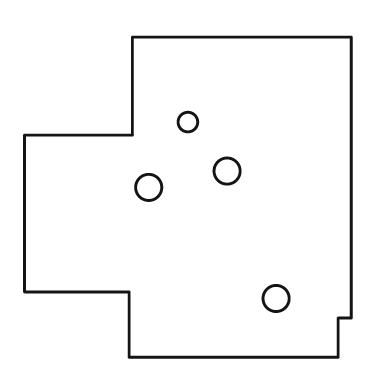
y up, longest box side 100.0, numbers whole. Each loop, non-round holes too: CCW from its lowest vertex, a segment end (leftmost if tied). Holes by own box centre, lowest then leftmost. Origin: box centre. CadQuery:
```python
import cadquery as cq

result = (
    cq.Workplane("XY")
    .moveTo(-18.0, -49.0)
    .lineTo(46.0, -49.0)
    .lineTo(46.0, -37.0)
    .lineTo(50.0, -37.0)
    .lineTo(50.0, 49.0)
    .lineTo(-17.0, 49.0)
    .lineTo(-17.0, 19.0)
    .lineTo(-50.0, 19.0)
    .lineTo(-50.0, -29.0)
    .lineTo(-18.0, -29.0)
    .close()
    .moveTo(27.0, -31.0)
    .circle(4.0)
    .moveTo(-12.0, 3.0)
    .circle(4.0)
    .moveTo(12.0, 8.0)
    .circle(4.0)
    .moveTo(0.0, 23.0)
    .circle(3.0)
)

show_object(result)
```